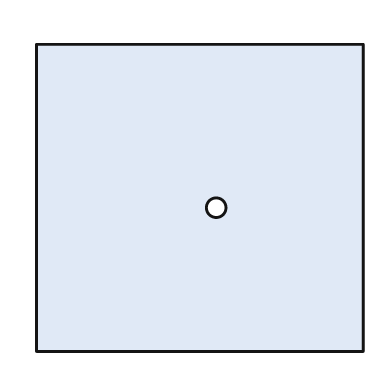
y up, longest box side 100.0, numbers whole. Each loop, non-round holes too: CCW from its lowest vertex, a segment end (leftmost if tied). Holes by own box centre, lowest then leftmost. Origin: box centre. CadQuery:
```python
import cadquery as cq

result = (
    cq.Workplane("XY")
    .moveTo(-50.0, -47.0)
    .lineTo(50.0, -47.0)
    .lineTo(50.0, 47.0)
    .lineTo(-50.0, 47.0)
    .close()
    .moveTo(5.0, -3.0)
    .circle(3.0)
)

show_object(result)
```